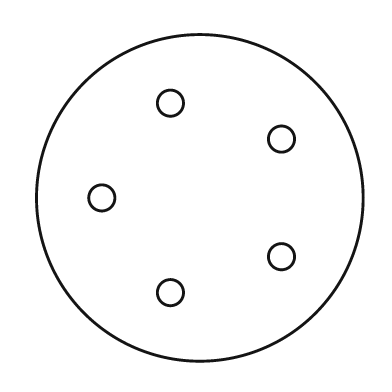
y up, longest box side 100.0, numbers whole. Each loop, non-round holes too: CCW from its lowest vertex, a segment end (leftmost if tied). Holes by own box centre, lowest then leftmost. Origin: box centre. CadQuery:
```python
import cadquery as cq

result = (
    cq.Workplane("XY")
    .moveTo(0.0, 0.0)
    .circle(50.0)
    .moveTo(-9.0, -29.0)
    .circle(4.0)
    .moveTo(25.0, -18.0)
    .circle(4.0)
    .moveTo(-30.0, 0.0)
    .circle(4.0)
    .moveTo(25.0, 18.0)
    .circle(4.0)
    .moveTo(-9.0, 29.0)
    .circle(4.0)
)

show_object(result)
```